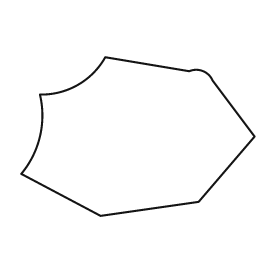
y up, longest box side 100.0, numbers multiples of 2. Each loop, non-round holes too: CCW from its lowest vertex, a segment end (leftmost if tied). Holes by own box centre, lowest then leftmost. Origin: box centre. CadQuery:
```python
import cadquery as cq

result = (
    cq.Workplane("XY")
    .moveTo(-16.0, -34.0)
    .lineTo(26.0, -28.0)
    .lineTo(50.0, 0.0)
    .lineTo(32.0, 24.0)
    .threePointArc((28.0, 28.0), (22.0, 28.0))
    .lineTo(-14.0, 34.0)
    .threePointArc((-26.0, 22.0), (-42.0, 18.0))
    .threePointArc((-42.0, 0.0), (-50.0, -16.0))
    .close()
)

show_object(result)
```